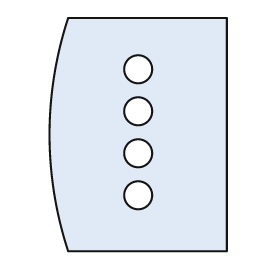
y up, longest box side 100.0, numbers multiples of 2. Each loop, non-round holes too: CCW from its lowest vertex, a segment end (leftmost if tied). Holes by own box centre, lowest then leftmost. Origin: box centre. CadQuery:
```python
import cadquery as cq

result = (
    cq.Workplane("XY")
    .moveTo(-30.0, -50.0)
    .lineTo(38.0, -50.0)
    .lineTo(38.0, 50.0)
    .lineTo(-30.0, 50.0)
    .threePointArc((-38.0, 0.0), (-30.0, -50.0))
    .close()
    .moveTo(0.0, -26.0)
    .circle(6.0)
    .moveTo(0.0, -8.0)
    .circle(6.0)
    .moveTo(0.0, 10.0)
    .circle(6.0)
    .moveTo(0.0, 28.0)
    .circle(6.0)
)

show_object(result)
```